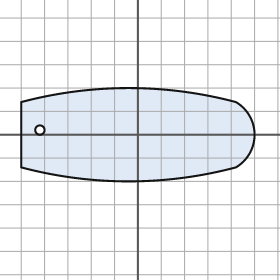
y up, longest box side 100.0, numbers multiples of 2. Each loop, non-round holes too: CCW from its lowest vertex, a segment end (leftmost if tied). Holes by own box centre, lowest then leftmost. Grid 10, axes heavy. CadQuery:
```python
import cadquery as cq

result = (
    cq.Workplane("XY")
    .moveTo(-50.0, -14.0)
    .threePointArc((-4.0, -20.0), (42.0, -14.0))
    .threePointArc((50.0, 0.0), (42.0, 14.0))
    .threePointArc((-4.0, 20.0), (-50.0, 14.0))
    .close()
    .moveTo(-42.0, 2.0)
    .circle(2.0)
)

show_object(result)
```